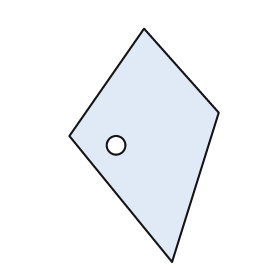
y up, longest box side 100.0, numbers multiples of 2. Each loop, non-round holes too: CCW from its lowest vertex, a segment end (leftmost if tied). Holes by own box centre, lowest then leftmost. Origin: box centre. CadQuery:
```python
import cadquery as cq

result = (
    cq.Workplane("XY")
    .moveTo(12.0, -50.0)
    .lineTo(32.0, 14.0)
    .lineTo(0.0, 50.0)
    .lineTo(-32.0, 4.0)
    .close()
    .moveTo(-12.0, 0.0)
    .circle(4.0)
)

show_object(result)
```